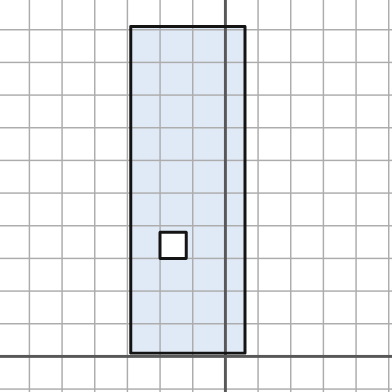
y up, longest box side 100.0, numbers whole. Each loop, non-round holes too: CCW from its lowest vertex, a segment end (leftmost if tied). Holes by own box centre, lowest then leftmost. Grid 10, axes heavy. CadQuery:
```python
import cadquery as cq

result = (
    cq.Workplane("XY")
    .moveTo(-29.0, 1.0)
    .lineTo(6.0, 1.0)
    .lineTo(6.0, 101.0)
    .lineTo(-29.0, 101.0)
    .close()
    .moveTo(-20.0, 30.0)
    .lineTo(-12.0, 30.0)
    .lineTo(-12.0, 38.0)
    .lineTo(-20.0, 38.0)
    .close()
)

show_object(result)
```